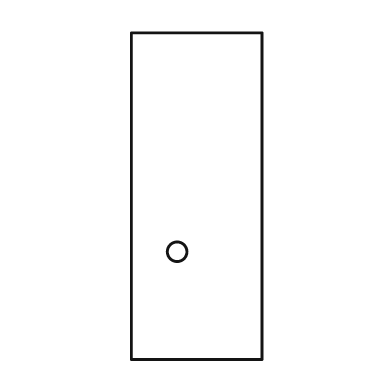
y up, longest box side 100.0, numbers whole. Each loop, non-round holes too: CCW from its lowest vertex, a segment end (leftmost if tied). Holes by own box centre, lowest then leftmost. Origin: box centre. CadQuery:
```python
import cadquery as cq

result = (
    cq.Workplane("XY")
    .moveTo(-20.0, -50.0)
    .lineTo(20.0, -50.0)
    .lineTo(20.0, 50.0)
    .lineTo(-20.0, 50.0)
    .close()
    .moveTo(-6.0, -17.0)
    .circle(3.0)
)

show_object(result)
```